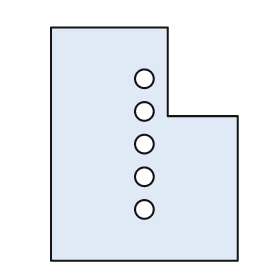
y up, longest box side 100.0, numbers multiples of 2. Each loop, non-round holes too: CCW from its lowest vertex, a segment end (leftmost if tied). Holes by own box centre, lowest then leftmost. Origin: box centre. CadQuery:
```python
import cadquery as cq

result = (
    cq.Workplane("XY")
    .moveTo(-40.0, -50.0)
    .lineTo(40.0, -50.0)
    .lineTo(40.0, 12.0)
    .lineTo(10.0, 12.0)
    .lineTo(10.0, 50.0)
    .lineTo(-40.0, 50.0)
    .close()
    .moveTo(0.0, -28.0)
    .circle(4.0)
    .moveTo(0.0, -14.0)
    .circle(4.0)
    .moveTo(0.0, 0.0)
    .circle(4.0)
    .moveTo(0.0, 14.0)
    .circle(4.0)
    .moveTo(0.0, 28.0)
    .circle(4.0)
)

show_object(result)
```